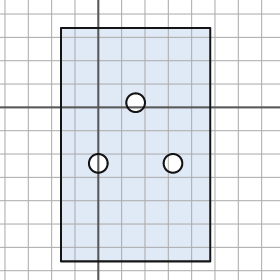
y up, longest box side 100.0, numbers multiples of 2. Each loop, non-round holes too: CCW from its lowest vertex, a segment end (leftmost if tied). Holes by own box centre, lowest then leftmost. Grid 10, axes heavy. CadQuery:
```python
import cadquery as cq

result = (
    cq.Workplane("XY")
    .moveTo(-16.0, -66.0)
    .lineTo(48.0, -66.0)
    .lineTo(48.0, 34.0)
    .lineTo(-16.0, 34.0)
    .close()
    .moveTo(0.0, -24.0)
    .circle(4.0)
    .moveTo(32.0, -24.0)
    .circle(4.0)
    .moveTo(16.0, 2.0)
    .circle(4.0)
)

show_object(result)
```